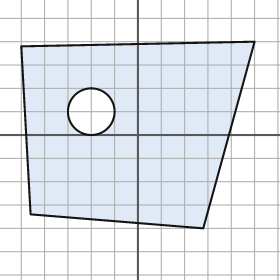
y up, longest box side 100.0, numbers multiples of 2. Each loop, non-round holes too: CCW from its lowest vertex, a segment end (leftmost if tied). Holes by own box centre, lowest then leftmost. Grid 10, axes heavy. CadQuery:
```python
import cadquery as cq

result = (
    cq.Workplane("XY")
    .moveTo(28.0, -40.0)
    .lineTo(50.0, 40.0)
    .lineTo(-50.0, 38.0)
    .lineTo(-46.0, -34.0)
    .close()
    .moveTo(-20.0, 10.0)
    .circle(10.0)
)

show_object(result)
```